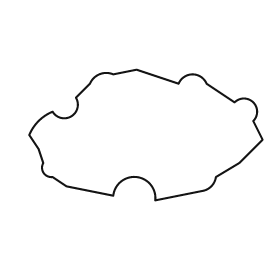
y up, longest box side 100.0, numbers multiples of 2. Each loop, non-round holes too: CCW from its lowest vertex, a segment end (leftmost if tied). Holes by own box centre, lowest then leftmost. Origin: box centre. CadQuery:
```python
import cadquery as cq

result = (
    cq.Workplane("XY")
    .moveTo(4.0, -28.0)
    .lineTo(24.0, -24.0)
    .threePointArc((28.0, -22.0), (30.0, -18.0))
    .lineTo(40.0, -12.0)
    .lineTo(50.0, -2.0)
    .lineTo(46.0, 6.0)
    .threePointArc((46.0, 14.0), (38.0, 14.0))
    .lineTo(26.0, 22.0)
    .threePointArc((20.0, 26.0), (14.0, 22.0))
    .lineTo(-4.0, 28.0)
    .lineTo(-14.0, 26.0)
    .threePointArc((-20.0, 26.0), (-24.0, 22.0))
    .lineTo(-30.0, 16.0)
    .threePointArc((-32.0, 8.0), (-40.0, 10.0))
    .threePointArc((-46.0, 6.0), (-50.0, 0.0))
    .lineTo(-46.0, -6.0)
    .lineTo(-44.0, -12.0)
    .threePointArc((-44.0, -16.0), (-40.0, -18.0))
    .lineTo(-34.0, -22.0)
    .lineTo(-14.0, -26.0)
    .threePointArc((-4.0, -18.0), (4.0, -28.0))
    .close()
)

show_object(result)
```